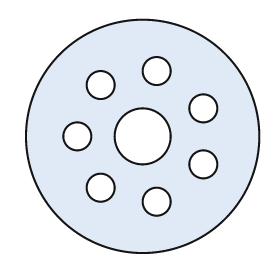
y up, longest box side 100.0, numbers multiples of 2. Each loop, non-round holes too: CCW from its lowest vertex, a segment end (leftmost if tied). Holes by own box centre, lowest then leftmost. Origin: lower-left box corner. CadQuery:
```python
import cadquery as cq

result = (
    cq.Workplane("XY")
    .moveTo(50.0, 50.0)
    .circle(50.0)
    .moveTo(56.0, 22.0)
    .circle(6.0)
    .moveTo(32.0, 28.0)
    .circle(6.0)
    .moveTo(76.0, 38.0)
    .circle(6.0)
    .moveTo(22.0, 50.0)
    .circle(6.0)
    .moveTo(50.0, 50.0)
    .circle(12.0)
    .moveTo(76.0, 62.0)
    .circle(6.0)
    .moveTo(32.0, 72.0)
    .circle(6.0)
    .moveTo(56.0, 78.0)
    .circle(6.0)
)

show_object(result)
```